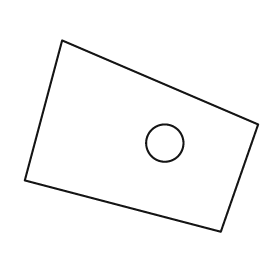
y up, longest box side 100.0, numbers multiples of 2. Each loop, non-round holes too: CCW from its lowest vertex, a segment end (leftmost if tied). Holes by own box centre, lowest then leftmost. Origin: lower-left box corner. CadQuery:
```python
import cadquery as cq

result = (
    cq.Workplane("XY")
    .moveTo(84.0, 0.0)
    .lineTo(100.0, 46.0)
    .lineTo(16.0, 82.0)
    .lineTo(0.0, 22.0)
    .close()
    .moveTo(60.0, 38.0)
    .circle(8.0)
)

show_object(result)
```